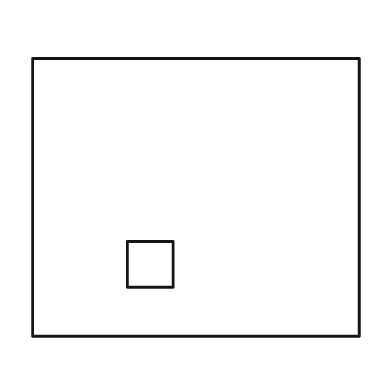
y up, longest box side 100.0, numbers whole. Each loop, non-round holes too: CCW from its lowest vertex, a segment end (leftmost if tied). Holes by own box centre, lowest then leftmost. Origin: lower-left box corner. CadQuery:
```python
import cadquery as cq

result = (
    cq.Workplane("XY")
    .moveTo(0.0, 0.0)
    .lineTo(100.0, 0.0)
    .lineTo(100.0, 85.0)
    .lineTo(0.0, 85.0)
    .close()
    .moveTo(29.0, 15.0)
    .lineTo(43.0, 15.0)
    .lineTo(43.0, 29.0)
    .lineTo(29.0, 29.0)
    .close()
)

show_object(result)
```